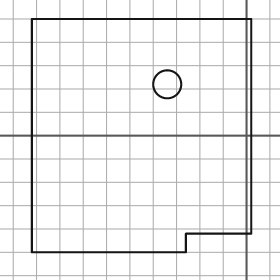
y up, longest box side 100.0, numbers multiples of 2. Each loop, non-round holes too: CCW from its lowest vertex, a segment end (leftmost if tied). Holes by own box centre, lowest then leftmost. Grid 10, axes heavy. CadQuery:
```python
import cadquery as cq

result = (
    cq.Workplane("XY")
    .moveTo(-92.0, -50.0)
    .lineTo(-26.0, -50.0)
    .lineTo(-26.0, -42.0)
    .lineTo(2.0, -42.0)
    .lineTo(2.0, 50.0)
    .lineTo(-92.0, 50.0)
    .close()
    .moveTo(-34.0, 22.0)
    .circle(6.0)
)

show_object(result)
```